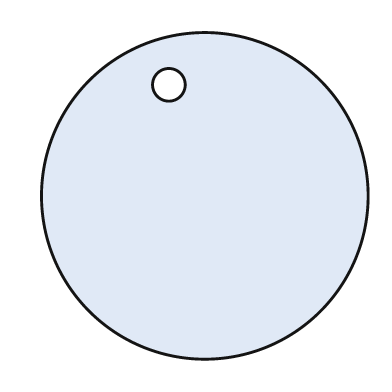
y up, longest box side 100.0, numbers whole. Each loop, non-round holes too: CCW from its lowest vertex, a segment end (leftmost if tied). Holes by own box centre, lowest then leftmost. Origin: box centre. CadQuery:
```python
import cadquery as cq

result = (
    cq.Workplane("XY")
    .moveTo(0.0, 0.0)
    .circle(50.0)
    .moveTo(-11.0, 34.0)
    .circle(5.0)
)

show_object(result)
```